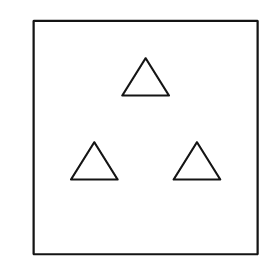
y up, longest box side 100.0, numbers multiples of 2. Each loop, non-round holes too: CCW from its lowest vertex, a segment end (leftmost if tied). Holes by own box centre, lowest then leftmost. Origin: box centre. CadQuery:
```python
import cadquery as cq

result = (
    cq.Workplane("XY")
    .moveTo(-48.0, -50.0)
    .lineTo(48.0, -50.0)
    .lineTo(48.0, 50.0)
    .lineTo(-48.0, 50.0)
    .close()
    .moveTo(-32.0, -18.0)
    .lineTo(-12.0, -18.0)
    .lineTo(-22.0, -2.0)
    .close()
    .moveTo(12.0, -18.0)
    .lineTo(32.0, -18.0)
    .lineTo(22.0, -2.0)
    .close()
    .moveTo(-10.0, 18.0)
    .lineTo(10.0, 18.0)
    .lineTo(0.0, 34.0)
    .close()
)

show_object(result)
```